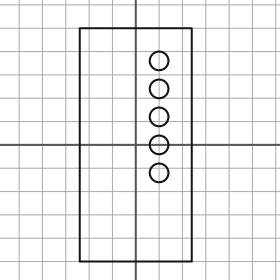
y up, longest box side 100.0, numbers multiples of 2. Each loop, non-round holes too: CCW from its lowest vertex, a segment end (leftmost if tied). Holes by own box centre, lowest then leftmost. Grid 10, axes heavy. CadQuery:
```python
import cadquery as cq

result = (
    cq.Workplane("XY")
    .moveTo(-24.0, -50.0)
    .lineTo(24.0, -50.0)
    .lineTo(24.0, 50.0)
    .lineTo(-24.0, 50.0)
    .close()
    .moveTo(10.0, -12.0)
    .circle(4.0)
    .moveTo(10.0, 0.0)
    .circle(4.0)
    .moveTo(10.0, 12.0)
    .circle(4.0)
    .moveTo(10.0, 24.0)
    .circle(4.0)
    .moveTo(10.0, 36.0)
    .circle(4.0)
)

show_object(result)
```